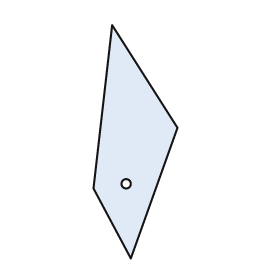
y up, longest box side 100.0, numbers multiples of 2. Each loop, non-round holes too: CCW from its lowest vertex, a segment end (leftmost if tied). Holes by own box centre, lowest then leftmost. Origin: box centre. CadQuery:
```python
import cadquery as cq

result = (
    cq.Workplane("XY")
    .moveTo(-2.0, -50.0)
    .lineTo(18.0, 6.0)
    .lineTo(-10.0, 50.0)
    .lineTo(-18.0, -20.0)
    .close()
    .moveTo(-4.0, -18.0)
    .circle(2.0)
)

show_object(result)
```